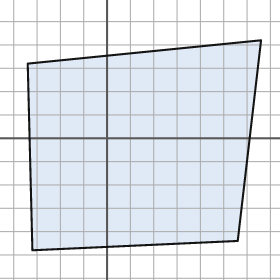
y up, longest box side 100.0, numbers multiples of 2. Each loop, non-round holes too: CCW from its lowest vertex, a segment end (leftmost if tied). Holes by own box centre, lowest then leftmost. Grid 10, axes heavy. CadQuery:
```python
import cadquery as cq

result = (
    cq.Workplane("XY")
    .moveTo(-32.0, -48.0)
    .lineTo(56.0, -44.0)
    .lineTo(66.0, 42.0)
    .lineTo(-34.0, 32.0)
    .close()
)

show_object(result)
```